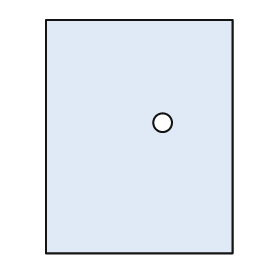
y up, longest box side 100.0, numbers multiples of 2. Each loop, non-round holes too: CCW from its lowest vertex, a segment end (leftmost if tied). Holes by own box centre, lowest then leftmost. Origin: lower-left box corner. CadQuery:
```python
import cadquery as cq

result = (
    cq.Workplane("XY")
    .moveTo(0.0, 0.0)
    .lineTo(80.0, 0.0)
    .lineTo(80.0, 100.0)
    .lineTo(0.0, 100.0)
    .close()
    .moveTo(50.0, 56.0)
    .circle(4.0)
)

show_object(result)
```